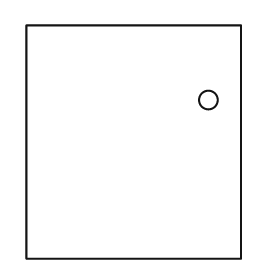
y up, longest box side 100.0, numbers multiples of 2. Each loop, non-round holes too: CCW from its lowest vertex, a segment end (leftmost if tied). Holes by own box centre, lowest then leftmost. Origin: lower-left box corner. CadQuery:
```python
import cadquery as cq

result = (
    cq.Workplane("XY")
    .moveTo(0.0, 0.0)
    .lineTo(92.0, 0.0)
    .lineTo(92.0, 100.0)
    .lineTo(0.0, 100.0)
    .close()
    .moveTo(78.0, 68.0)
    .circle(4.0)
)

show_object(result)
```